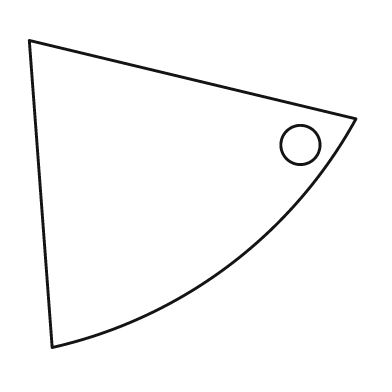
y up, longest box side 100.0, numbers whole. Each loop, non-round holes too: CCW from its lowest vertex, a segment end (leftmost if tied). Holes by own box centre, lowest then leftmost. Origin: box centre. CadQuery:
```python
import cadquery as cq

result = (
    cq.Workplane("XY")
    .moveTo(-43.0, -47.0)
    .threePointArc((11.0, -22.0), (50.0, 23.0))
    .lineTo(-50.0, 47.0)
    .close()
    .moveTo(33.0, 15.0)
    .circle(6.0)
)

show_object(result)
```